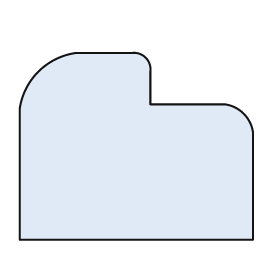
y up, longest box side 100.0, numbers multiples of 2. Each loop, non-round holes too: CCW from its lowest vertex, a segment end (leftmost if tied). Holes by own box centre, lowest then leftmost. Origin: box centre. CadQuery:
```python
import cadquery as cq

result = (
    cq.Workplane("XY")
    .moveTo(-50.0, -40.0)
    .lineTo(50.0, -40.0)
    .lineTo(50.0, 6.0)
    .threePointArc((46.0, 14.0), (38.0, 18.0))
    .lineTo(6.0, 18.0)
    .lineTo(6.0, 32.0)
    .threePointArc((4.0, 38.0), (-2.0, 40.0))
    .lineTo(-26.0, 40.0)
    .threePointArc((-42.0, 32.0), (-50.0, 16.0))
    .close()
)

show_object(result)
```